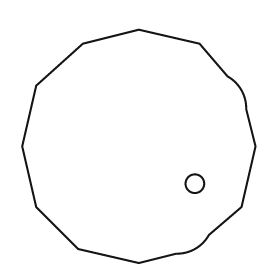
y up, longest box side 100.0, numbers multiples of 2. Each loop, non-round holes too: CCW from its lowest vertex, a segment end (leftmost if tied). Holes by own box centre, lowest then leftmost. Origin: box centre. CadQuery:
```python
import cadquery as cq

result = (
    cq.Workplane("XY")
    .moveTo(0.0, -50.0)
    .lineTo(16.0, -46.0)
    .threePointArc((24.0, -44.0), (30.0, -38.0))
    .lineTo(44.0, -26.0)
    .lineTo(50.0, 0.0)
    .lineTo(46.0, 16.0)
    .threePointArc((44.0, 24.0), (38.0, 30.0))
    .lineTo(26.0, 44.0)
    .lineTo(0.0, 50.0)
    .lineTo(-24.0, 44.0)
    .lineTo(-44.0, 26.0)
    .lineTo(-50.0, 0.0)
    .lineTo(-44.0, -26.0)
    .lineTo(-26.0, -44.0)
    .close()
    .moveTo(24.0, -16.0)
    .circle(4.0)
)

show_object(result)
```